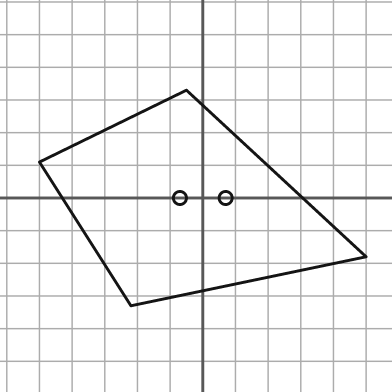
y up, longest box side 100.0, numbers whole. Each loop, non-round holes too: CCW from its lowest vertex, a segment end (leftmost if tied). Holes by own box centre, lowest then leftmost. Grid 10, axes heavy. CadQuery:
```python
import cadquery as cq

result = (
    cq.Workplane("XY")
    .moveTo(-22.0, -33.0)
    .lineTo(50.0, -18.0)
    .lineTo(-5.0, 33.0)
    .lineTo(-50.0, 11.0)
    .close()
    .moveTo(-7.0, 0.0)
    .circle(2.0)
    .moveTo(7.0, 0.0)
    .circle(2.0)
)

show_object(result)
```